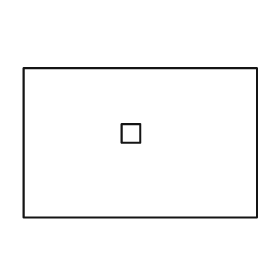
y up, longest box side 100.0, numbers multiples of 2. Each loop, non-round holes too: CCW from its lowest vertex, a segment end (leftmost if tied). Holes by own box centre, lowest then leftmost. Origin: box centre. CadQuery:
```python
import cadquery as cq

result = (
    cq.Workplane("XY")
    .moveTo(-50.0, -32.0)
    .lineTo(50.0, -32.0)
    .lineTo(50.0, 32.0)
    .lineTo(-50.0, 32.0)
    .close()
    .moveTo(-8.0, 0.0)
    .lineTo(0.0, 0.0)
    .lineTo(0.0, 8.0)
    .lineTo(-8.0, 8.0)
    .close()
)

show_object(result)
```